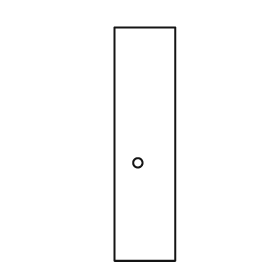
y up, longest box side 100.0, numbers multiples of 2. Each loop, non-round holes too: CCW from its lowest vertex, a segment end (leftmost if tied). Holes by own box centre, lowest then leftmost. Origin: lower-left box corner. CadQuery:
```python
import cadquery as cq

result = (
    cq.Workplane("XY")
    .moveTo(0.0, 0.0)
    .lineTo(26.0, 0.0)
    .lineTo(26.0, 100.0)
    .lineTo(0.0, 100.0)
    .close()
    .moveTo(10.0, 42.0)
    .circle(2.0)
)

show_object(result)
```